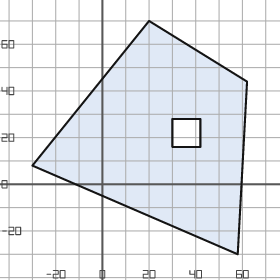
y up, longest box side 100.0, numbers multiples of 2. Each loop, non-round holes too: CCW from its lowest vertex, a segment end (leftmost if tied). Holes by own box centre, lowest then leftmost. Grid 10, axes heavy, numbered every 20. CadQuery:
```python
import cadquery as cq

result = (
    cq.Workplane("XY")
    .moveTo(58.0, -30.0)
    .lineTo(62.0, 44.0)
    .lineTo(20.0, 70.0)
    .lineTo(-30.0, 8.0)
    .close()
    .moveTo(30.0, 16.0)
    .lineTo(42.0, 16.0)
    .lineTo(42.0, 28.0)
    .lineTo(30.0, 28.0)
    .close()
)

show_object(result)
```